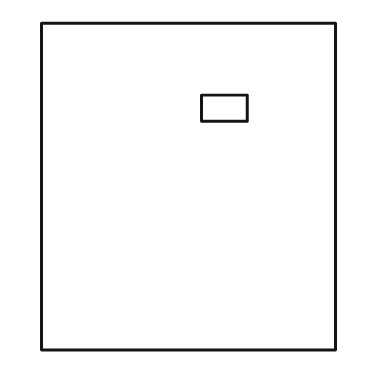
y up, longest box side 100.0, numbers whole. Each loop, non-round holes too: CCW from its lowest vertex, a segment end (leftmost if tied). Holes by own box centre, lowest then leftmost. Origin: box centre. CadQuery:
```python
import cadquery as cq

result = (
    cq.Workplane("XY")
    .moveTo(-45.0, -50.0)
    .lineTo(45.0, -50.0)
    .lineTo(45.0, 50.0)
    .lineTo(-45.0, 50.0)
    .close()
    .moveTo(4.0, 20.0)
    .lineTo(18.0, 20.0)
    .lineTo(18.0, 28.0)
    .lineTo(4.0, 28.0)
    .close()
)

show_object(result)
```